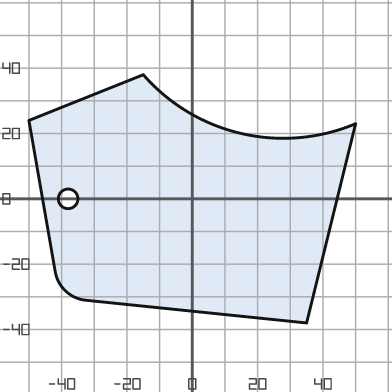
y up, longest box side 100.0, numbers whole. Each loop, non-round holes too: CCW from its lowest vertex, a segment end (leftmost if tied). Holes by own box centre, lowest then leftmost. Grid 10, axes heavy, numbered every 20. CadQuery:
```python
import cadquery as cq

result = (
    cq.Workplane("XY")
    .moveTo(35.0, -38.0)
    .lineTo(50.0, 23.0)
    .threePointArc((15.0, 20.0), (-15.0, 38.0))
    .lineTo(-50.0, 24.0)
    .lineTo(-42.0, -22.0)
    .threePointArc((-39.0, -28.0), (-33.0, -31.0))
    .close()
    .moveTo(-38.0, 0.0)
    .circle(3.0)
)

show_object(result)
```